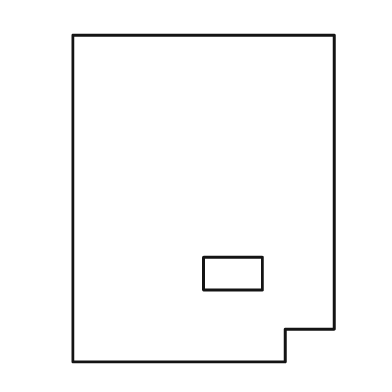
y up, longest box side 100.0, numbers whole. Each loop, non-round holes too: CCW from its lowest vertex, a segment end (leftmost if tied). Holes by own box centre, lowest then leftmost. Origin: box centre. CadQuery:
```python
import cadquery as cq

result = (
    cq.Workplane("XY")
    .moveTo(-40.0, -50.0)
    .lineTo(25.0, -50.0)
    .lineTo(25.0, -40.0)
    .lineTo(40.0, -40.0)
    .lineTo(40.0, 50.0)
    .lineTo(-40.0, 50.0)
    .close()
    .moveTo(0.0, -28.0)
    .lineTo(18.0, -28.0)
    .lineTo(18.0, -18.0)
    .lineTo(0.0, -18.0)
    .close()
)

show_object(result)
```